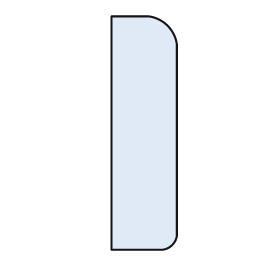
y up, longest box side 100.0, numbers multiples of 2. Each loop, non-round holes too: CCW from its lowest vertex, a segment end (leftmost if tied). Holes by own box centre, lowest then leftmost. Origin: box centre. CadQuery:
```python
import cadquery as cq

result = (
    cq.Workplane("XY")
    .moveTo(-14.0, -50.0)
    .lineTo(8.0, -50.0)
    .threePointArc((12.0, -48.0), (14.0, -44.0))
    .lineTo(14.0, 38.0)
    .threePointArc((10.0, 46.0), (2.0, 50.0))
    .lineTo(-14.0, 50.0)
    .close()
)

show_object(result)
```